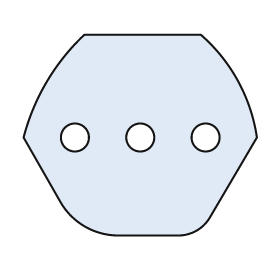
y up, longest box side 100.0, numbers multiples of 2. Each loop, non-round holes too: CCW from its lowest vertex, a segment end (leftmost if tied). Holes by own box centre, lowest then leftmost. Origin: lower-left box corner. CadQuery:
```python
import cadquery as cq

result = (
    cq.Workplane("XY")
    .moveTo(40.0, 0.0)
    .lineTo(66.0, 0.0)
    .threePointArc((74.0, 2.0), (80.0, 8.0))
    .lineTo(100.0, 42.0)
    .threePointArc((92.0, 66.0), (76.0, 86.0))
    .lineTo(26.0, 86.0)
    .threePointArc((10.0, 66.0), (0.0, 42.0))
    .lineTo(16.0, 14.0)
    .threePointArc((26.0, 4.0), (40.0, 0.0))
    .close()
    .moveTo(22.0, 42.0)
    .circle(6.0)
    .moveTo(50.0, 42.0)
    .circle(6.0)
    .moveTo(78.0, 42.0)
    .circle(6.0)
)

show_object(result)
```